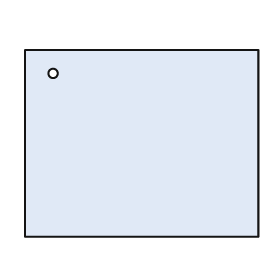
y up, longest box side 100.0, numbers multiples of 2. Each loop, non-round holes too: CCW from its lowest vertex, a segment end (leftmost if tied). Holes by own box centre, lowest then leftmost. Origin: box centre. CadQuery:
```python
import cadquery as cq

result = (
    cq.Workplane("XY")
    .moveTo(-50.0, -40.0)
    .lineTo(50.0, -40.0)
    .lineTo(50.0, 40.0)
    .lineTo(-50.0, 40.0)
    .close()
    .moveTo(-38.0, 30.0)
    .circle(2.0)
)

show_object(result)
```